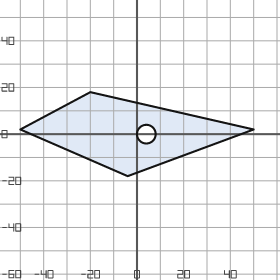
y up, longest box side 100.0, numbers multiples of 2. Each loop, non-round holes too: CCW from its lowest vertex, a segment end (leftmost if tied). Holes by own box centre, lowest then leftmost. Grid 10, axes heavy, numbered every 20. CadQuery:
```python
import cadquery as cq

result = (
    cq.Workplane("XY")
    .moveTo(-4.0, -18.0)
    .lineTo(50.0, 2.0)
    .lineTo(-20.0, 18.0)
    .lineTo(-50.0, 2.0)
    .close()
    .moveTo(4.0, 0.0)
    .circle(4.0)
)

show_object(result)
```